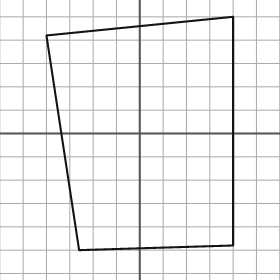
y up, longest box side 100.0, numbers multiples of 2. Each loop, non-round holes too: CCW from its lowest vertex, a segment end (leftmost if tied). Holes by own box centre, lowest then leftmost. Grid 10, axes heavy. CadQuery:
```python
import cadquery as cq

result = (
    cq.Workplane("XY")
    .moveTo(-26.0, -50.0)
    .lineTo(40.0, -48.0)
    .lineTo(40.0, 50.0)
    .lineTo(-40.0, 42.0)
    .close()
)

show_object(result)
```